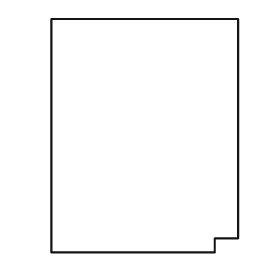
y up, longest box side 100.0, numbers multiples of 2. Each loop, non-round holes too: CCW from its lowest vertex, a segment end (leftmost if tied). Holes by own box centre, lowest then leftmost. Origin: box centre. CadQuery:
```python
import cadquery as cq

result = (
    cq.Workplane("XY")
    .moveTo(-40.0, -50.0)
    .lineTo(30.0, -50.0)
    .lineTo(30.0, -44.0)
    .lineTo(40.0, -44.0)
    .lineTo(40.0, 50.0)
    .lineTo(-40.0, 50.0)
    .close()
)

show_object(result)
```